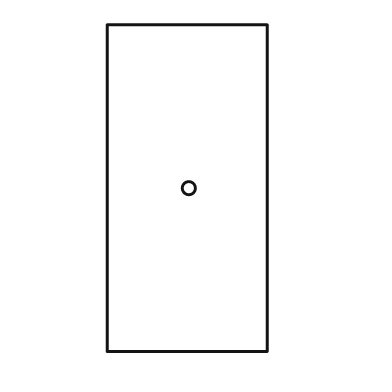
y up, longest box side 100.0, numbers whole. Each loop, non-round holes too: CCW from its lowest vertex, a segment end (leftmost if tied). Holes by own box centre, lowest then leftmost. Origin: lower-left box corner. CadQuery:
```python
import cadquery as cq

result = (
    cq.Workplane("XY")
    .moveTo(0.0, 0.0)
    .lineTo(49.0, 0.0)
    .lineTo(49.0, 100.0)
    .lineTo(0.0, 100.0)
    .close()
    .moveTo(25.0, 50.0)
    .circle(2.0)
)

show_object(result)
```